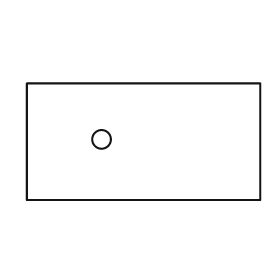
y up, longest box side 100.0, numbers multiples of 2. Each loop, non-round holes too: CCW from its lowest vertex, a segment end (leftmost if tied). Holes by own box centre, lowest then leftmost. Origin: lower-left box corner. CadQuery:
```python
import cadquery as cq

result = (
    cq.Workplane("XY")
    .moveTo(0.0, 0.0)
    .lineTo(100.0, 0.0)
    .lineTo(100.0, 50.0)
    .lineTo(0.0, 50.0)
    .close()
    .moveTo(32.0, 26.0)
    .circle(4.0)
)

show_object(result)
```